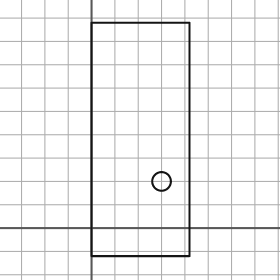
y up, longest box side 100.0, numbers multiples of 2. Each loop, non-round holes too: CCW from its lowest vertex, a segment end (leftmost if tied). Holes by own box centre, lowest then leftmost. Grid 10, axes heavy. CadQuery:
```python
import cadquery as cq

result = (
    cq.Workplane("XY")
    .moveTo(0.0, -12.0)
    .lineTo(42.0, -12.0)
    .lineTo(42.0, 88.0)
    .lineTo(0.0, 88.0)
    .close()
    .moveTo(30.0, 20.0)
    .circle(4.0)
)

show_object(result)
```